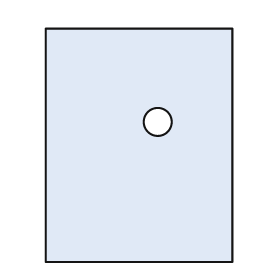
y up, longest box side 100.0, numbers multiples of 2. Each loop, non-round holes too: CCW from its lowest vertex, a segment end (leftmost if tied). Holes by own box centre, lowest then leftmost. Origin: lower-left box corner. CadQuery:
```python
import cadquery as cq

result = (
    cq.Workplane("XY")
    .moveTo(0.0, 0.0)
    .lineTo(80.0, 0.0)
    .lineTo(80.0, 100.0)
    .lineTo(0.0, 100.0)
    .close()
    .moveTo(48.0, 60.0)
    .circle(6.0)
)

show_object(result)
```